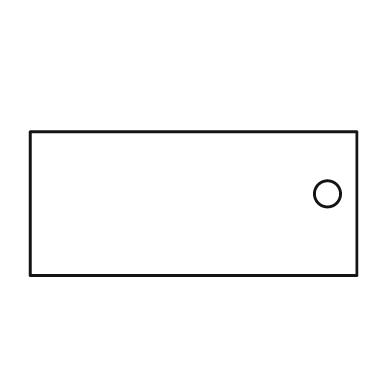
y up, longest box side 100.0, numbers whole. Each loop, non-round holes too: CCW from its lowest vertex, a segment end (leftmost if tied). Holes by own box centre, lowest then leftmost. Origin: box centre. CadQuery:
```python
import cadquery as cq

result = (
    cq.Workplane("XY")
    .moveTo(-50.0, -22.0)
    .lineTo(50.0, -22.0)
    .lineTo(50.0, 22.0)
    .lineTo(-50.0, 22.0)
    .close()
    .moveTo(41.0, 3.0)
    .circle(4.0)
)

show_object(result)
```